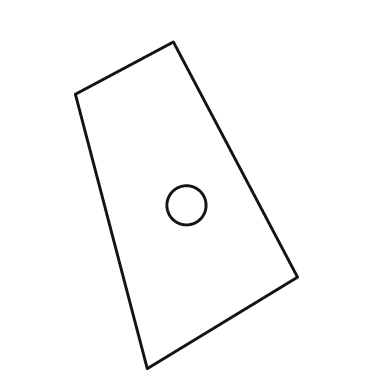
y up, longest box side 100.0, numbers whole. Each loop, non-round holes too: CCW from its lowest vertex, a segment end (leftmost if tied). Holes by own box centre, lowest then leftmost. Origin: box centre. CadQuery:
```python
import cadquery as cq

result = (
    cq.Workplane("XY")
    .moveTo(-12.0, -50.0)
    .lineTo(34.0, -22.0)
    .lineTo(-4.0, 50.0)
    .lineTo(-34.0, 34.0)
    .close()
    .moveTo(0.0, 0.0)
    .circle(6.0)
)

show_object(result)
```